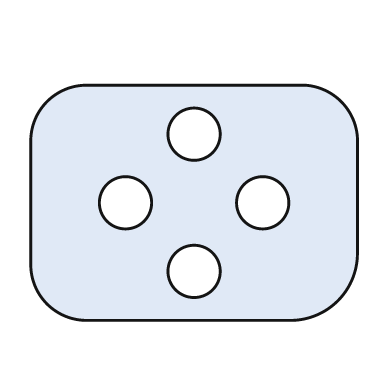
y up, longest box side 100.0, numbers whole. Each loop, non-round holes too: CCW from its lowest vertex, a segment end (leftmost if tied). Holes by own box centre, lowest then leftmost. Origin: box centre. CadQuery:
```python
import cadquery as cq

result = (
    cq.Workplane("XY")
    .moveTo(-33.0, -36.0)
    .lineTo(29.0, -36.0)
    .threePointArc((44.0, -30.0), (50.0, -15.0))
    .lineTo(50.0, 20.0)
    .threePointArc((45.0, 31.0), (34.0, 36.0))
    .lineTo(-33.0, 36.0)
    .threePointArc((-45.0, 31.0), (-50.0, 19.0))
    .lineTo(-50.0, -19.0)
    .threePointArc((-45.0, -31.0), (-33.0, -36.0))
    .close()
    .moveTo(0.0, -21.0)
    .circle(8.0)
    .moveTo(-21.0, 0.0)
    .circle(8.0)
    .moveTo(21.0, 0.0)
    .circle(8.0)
    .moveTo(0.0, 21.0)
    .circle(8.0)
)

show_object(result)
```